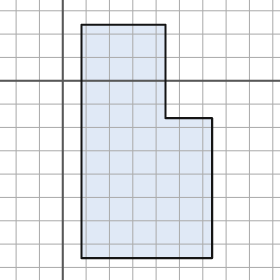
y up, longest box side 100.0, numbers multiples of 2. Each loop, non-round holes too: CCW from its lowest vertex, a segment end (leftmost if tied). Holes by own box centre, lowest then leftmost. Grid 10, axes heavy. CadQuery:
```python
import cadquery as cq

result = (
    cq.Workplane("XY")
    .moveTo(8.0, -76.0)
    .lineTo(64.0, -76.0)
    .lineTo(64.0, -16.0)
    .lineTo(44.0, -16.0)
    .lineTo(44.0, 24.0)
    .lineTo(8.0, 24.0)
    .close()
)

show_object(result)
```